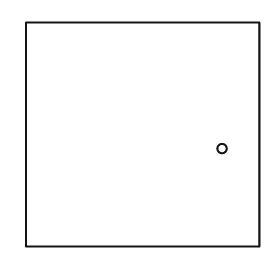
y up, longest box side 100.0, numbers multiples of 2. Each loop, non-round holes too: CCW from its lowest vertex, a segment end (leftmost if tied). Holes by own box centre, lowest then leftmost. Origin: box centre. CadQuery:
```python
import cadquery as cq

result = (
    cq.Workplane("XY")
    .moveTo(-50.0, -48.0)
    .lineTo(50.0, -48.0)
    .lineTo(50.0, 48.0)
    .lineTo(-50.0, 48.0)
    .close()
    .moveTo(34.0, -6.0)
    .circle(2.0)
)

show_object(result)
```